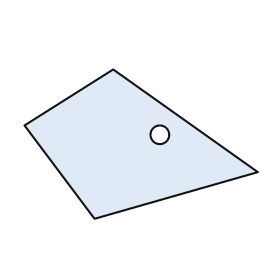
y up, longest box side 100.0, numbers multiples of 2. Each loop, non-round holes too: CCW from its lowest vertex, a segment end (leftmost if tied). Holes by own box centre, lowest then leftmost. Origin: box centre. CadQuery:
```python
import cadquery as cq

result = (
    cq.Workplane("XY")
    .moveTo(-20.0, -32.0)
    .lineTo(50.0, -12.0)
    .lineTo(-12.0, 32.0)
    .lineTo(-50.0, 8.0)
    .close()
    .moveTo(8.0, 4.0)
    .circle(4.0)
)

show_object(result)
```